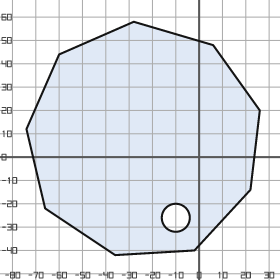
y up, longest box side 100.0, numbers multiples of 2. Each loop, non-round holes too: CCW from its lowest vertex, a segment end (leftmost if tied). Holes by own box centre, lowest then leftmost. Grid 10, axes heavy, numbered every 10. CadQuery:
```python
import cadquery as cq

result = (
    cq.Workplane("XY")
    .moveTo(-36.0, -42.0)
    .lineTo(-2.0, -40.0)
    .lineTo(22.0, -14.0)
    .lineTo(26.0, 20.0)
    .lineTo(6.0, 48.0)
    .lineTo(-28.0, 58.0)
    .lineTo(-60.0, 44.0)
    .lineTo(-74.0, 12.0)
    .lineTo(-66.0, -22.0)
    .close()
    .moveTo(-10.0, -26.0)
    .circle(6.0)
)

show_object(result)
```